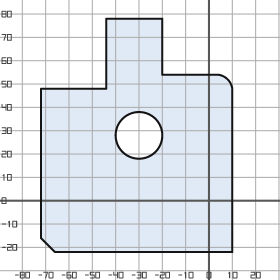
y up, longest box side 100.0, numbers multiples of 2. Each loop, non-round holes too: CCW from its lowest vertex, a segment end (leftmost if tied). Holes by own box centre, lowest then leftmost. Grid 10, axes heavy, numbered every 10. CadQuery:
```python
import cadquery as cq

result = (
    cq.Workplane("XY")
    .moveTo(-66.0, -22.0)
    .lineTo(10.0, -22.0)
    .lineTo(10.0, 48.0)
    .threePointArc((8.0, 52.0), (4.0, 54.0))
    .lineTo(-20.0, 54.0)
    .lineTo(-20.0, 78.0)
    .lineTo(-44.0, 78.0)
    .lineTo(-44.0, 48.0)
    .lineTo(-72.0, 48.0)
    .lineTo(-72.0, -16.0)
    .close()
    .moveTo(-30.0, 28.0)
    .circle(10.0)
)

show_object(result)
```